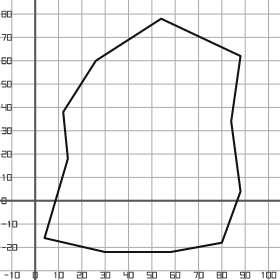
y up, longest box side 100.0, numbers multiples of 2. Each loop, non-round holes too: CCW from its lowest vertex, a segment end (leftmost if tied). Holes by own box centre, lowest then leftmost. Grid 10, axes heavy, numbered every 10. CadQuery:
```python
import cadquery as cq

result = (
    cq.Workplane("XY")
    .moveTo(30.0, -22.0)
    .lineTo(58.0, -22.0)
    .lineTo(80.0, -18.0)
    .lineTo(88.0, 4.0)
    .lineTo(84.0, 34.0)
    .lineTo(88.0, 62.0)
    .lineTo(54.0, 78.0)
    .lineTo(26.0, 60.0)
    .lineTo(12.0, 38.0)
    .lineTo(14.0, 18.0)
    .lineTo(4.0, -16.0)
    .close()
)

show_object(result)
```